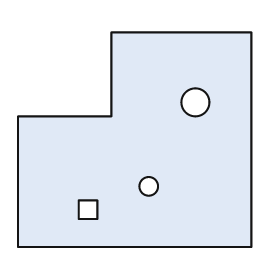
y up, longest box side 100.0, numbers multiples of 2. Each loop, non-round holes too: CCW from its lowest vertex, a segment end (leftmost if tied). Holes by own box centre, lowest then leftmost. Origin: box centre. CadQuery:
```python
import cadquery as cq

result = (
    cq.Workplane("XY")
    .moveTo(-50.0, -46.0)
    .lineTo(50.0, -46.0)
    .lineTo(50.0, 46.0)
    .lineTo(-10.0, 46.0)
    .lineTo(-10.0, 10.0)
    .lineTo(-50.0, 10.0)
    .close()
    .moveTo(-24.0, -34.0)
    .lineTo(-16.0, -34.0)
    .lineTo(-16.0, -26.0)
    .lineTo(-24.0, -26.0)
    .close()
    .moveTo(6.0, -20.0)
    .circle(4.0)
    .moveTo(26.0, 16.0)
    .circle(6.0)
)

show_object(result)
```